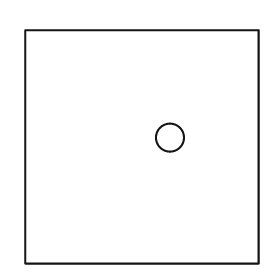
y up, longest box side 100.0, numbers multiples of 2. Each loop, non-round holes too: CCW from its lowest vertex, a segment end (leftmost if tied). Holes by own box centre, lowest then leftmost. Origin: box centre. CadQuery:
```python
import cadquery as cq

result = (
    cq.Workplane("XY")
    .moveTo(-50.0, -50.0)
    .lineTo(50.0, -50.0)
    .lineTo(50.0, 50.0)
    .lineTo(-50.0, 50.0)
    .close()
    .moveTo(12.0, 4.0)
    .circle(6.0)
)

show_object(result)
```